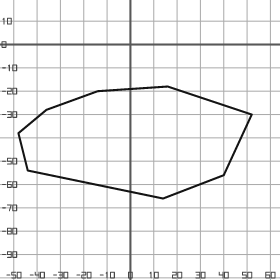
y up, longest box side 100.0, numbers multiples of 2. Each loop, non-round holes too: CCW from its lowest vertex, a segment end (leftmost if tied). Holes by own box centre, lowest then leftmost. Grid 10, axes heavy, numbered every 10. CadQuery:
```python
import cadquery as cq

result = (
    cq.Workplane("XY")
    .moveTo(14.0, -66.0)
    .lineTo(40.0, -56.0)
    .lineTo(52.0, -30.0)
    .lineTo(16.0, -18.0)
    .lineTo(-14.0, -20.0)
    .lineTo(-36.0, -28.0)
    .lineTo(-48.0, -38.0)
    .lineTo(-44.0, -54.0)
    .close()
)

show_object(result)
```